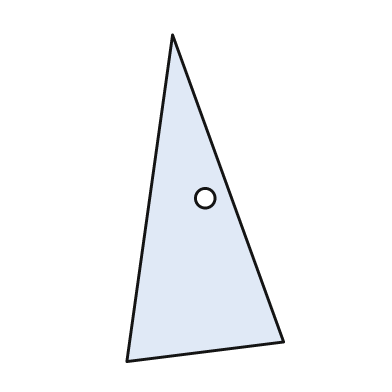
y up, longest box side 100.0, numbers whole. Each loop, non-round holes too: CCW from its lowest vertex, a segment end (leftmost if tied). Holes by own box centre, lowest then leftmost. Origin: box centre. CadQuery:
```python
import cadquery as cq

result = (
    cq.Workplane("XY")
    .moveTo(-24.0, -50.0)
    .lineTo(24.0, -44.0)
    .lineTo(-10.0, 50.0)
    .close()
    .moveTo(0.0, 0.0)
    .circle(3.0)
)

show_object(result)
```